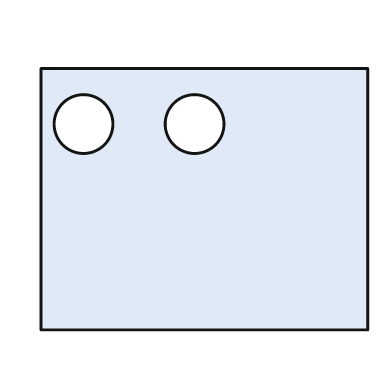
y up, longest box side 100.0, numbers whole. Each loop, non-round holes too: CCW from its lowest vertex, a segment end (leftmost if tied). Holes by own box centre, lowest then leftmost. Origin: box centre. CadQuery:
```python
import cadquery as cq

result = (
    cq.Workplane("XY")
    .moveTo(-50.0, -40.0)
    .lineTo(50.0, -40.0)
    .lineTo(50.0, 40.0)
    .lineTo(-50.0, 40.0)
    .close()
    .moveTo(-37.0, 23.0)
    .circle(9.0)
    .moveTo(-3.0, 23.0)
    .circle(9.0)
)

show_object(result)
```